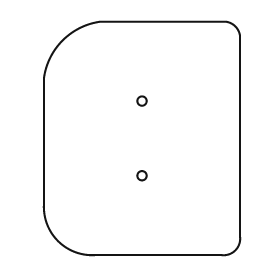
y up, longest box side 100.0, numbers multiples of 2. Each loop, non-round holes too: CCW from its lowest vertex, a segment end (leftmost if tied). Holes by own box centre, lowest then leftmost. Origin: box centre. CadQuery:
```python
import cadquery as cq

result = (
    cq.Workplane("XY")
    .moveTo(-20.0, -50.0)
    .lineTo(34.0, -50.0)
    .threePointArc((40.0, -48.0), (42.0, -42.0))
    .lineTo(42.0, 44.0)
    .threePointArc((40.0, 48.0), (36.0, 50.0))
    .lineTo(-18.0, 50.0)
    .threePointArc((-34.0, 42.0), (-42.0, 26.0))
    .lineTo(-42.0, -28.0)
    .threePointArc((-36.0, -44.0), (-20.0, -50.0))
    .close()
    .moveTo(0.0, -16.0)
    .circle(2.0)
    .moveTo(0.0, 16.0)
    .circle(2.0)
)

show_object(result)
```